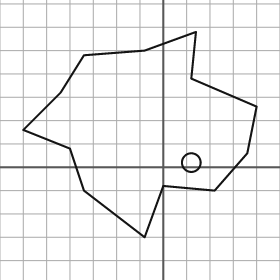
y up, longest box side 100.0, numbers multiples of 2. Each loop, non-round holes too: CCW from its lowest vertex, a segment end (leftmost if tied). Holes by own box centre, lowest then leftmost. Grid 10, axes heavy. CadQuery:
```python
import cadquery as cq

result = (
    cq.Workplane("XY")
    .moveTo(-8.0, -30.0)
    .lineTo(0.0, -8.0)
    .lineTo(22.0, -10.0)
    .lineTo(36.0, 6.0)
    .lineTo(40.0, 26.0)
    .lineTo(12.0, 38.0)
    .lineTo(14.0, 58.0)
    .lineTo(-8.0, 50.0)
    .lineTo(-34.0, 48.0)
    .lineTo(-44.0, 32.0)
    .lineTo(-60.0, 16.0)
    .lineTo(-40.0, 8.0)
    .lineTo(-34.0, -10.0)
    .close()
    .moveTo(12.0, 2.0)
    .circle(4.0)
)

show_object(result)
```